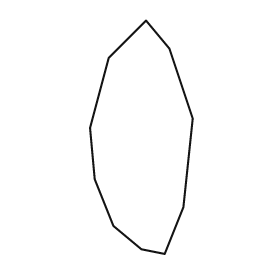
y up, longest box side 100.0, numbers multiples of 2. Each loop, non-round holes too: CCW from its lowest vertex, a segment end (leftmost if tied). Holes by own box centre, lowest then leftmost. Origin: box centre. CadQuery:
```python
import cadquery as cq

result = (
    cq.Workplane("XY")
    .moveTo(10.0, -50.0)
    .lineTo(18.0, -30.0)
    .lineTo(22.0, 8.0)
    .lineTo(12.0, 38.0)
    .lineTo(2.0, 50.0)
    .lineTo(-14.0, 34.0)
    .lineTo(-22.0, 4.0)
    .lineTo(-20.0, -18.0)
    .lineTo(-12.0, -38.0)
    .lineTo(0.0, -48.0)
    .close()
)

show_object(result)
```